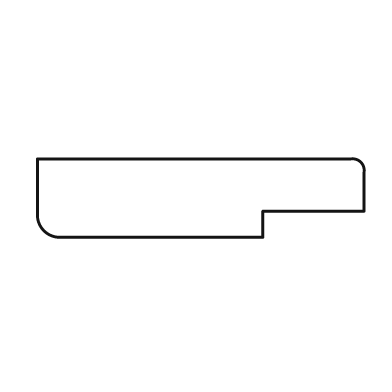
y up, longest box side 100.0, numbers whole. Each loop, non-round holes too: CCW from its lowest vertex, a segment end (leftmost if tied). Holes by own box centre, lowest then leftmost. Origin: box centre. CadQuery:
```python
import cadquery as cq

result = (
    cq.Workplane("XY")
    .moveTo(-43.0, -12.0)
    .lineTo(19.0, -12.0)
    .lineTo(19.0, -4.0)
    .lineTo(50.0, -4.0)
    .lineTo(50.0, 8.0)
    .threePointArc((49.0, 11.0), (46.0, 12.0))
    .lineTo(-50.0, 12.0)
    .lineTo(-50.0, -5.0)
    .threePointArc((-48.0, -10.0), (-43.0, -12.0))
    .close()
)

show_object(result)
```